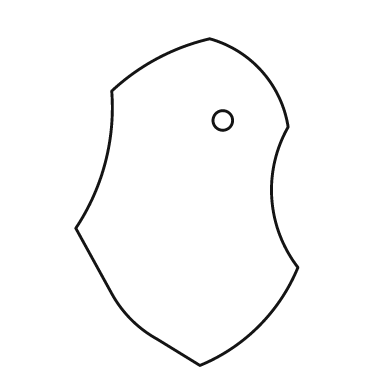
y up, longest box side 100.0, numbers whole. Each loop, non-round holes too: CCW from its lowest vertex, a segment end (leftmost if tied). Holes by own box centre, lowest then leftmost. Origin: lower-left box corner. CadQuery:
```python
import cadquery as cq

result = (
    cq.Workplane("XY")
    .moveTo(38.0, 0.0)
    .threePointArc((56.0, 12.0), (68.0, 30.0))
    .threePointArc((60.0, 51.0), (65.0, 73.0))
    .threePointArc((57.0, 90.0), (41.0, 100.0))
    .threePointArc((25.0, 94.0), (11.0, 84.0))
    .threePointArc((9.0, 62.0), (0.0, 42.0))
    .lineTo(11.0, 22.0)
    .threePointArc((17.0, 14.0), (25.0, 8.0))
    .close()
    .moveTo(45.0, 75.0)
    .circle(3.0)
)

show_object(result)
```